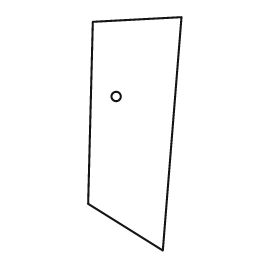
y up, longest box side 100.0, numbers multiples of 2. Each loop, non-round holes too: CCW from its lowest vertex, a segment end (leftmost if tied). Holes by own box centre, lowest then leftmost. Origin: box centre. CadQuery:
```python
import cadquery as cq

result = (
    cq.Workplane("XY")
    .moveTo(12.0, -50.0)
    .lineTo(20.0, 50.0)
    .lineTo(-18.0, 48.0)
    .lineTo(-20.0, -30.0)
    .close()
    .moveTo(-8.0, 16.0)
    .circle(2.0)
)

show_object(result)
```